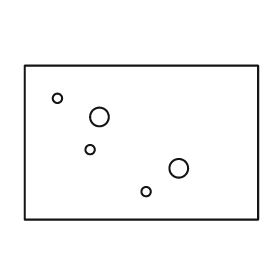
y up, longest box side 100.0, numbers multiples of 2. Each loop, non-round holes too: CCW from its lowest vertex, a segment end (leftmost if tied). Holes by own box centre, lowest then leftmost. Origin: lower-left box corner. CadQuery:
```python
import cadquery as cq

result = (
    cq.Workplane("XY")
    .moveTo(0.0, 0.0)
    .lineTo(100.0, 0.0)
    .lineTo(100.0, 66.0)
    .lineTo(0.0, 66.0)
    .close()
    .moveTo(52.0, 12.0)
    .circle(2.0)
    .moveTo(66.0, 22.0)
    .circle(4.0)
    .moveTo(28.0, 30.0)
    .circle(2.0)
    .moveTo(32.0, 44.0)
    .circle(4.0)
    .moveTo(14.0, 52.0)
    .circle(2.0)
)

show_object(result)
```